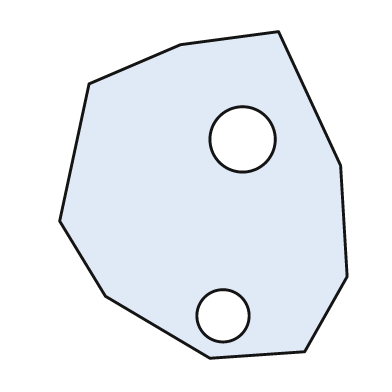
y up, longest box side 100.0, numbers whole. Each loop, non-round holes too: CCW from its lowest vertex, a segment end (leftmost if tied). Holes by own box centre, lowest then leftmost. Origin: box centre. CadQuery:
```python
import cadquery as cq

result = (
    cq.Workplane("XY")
    .moveTo(2.0, -50.0)
    .lineTo(31.0, -48.0)
    .lineTo(44.0, -25.0)
    .lineTo(42.0, 9.0)
    .lineTo(23.0, 50.0)
    .lineTo(-7.0, 46.0)
    .lineTo(-35.0, 34.0)
    .lineTo(-44.0, -8.0)
    .lineTo(-30.0, -31.0)
    .close()
    .moveTo(6.0, -37.0)
    .circle(8.0)
    .moveTo(12.0, 17.0)
    .circle(10.0)
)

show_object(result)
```